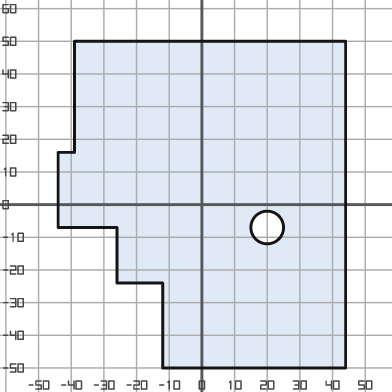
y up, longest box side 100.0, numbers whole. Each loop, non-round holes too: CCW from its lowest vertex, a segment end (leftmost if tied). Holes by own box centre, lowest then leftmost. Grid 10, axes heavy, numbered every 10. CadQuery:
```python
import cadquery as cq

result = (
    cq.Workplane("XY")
    .moveTo(-12.0, -50.0)
    .lineTo(44.0, -50.0)
    .lineTo(44.0, 50.0)
    .lineTo(-39.0, 50.0)
    .lineTo(-39.0, 16.0)
    .lineTo(-44.0, 16.0)
    .lineTo(-44.0, -7.0)
    .lineTo(-26.0, -7.0)
    .lineTo(-26.0, -24.0)
    .lineTo(-12.0, -24.0)
    .close()
    .moveTo(20.0, -7.0)
    .circle(5.0)
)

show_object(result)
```